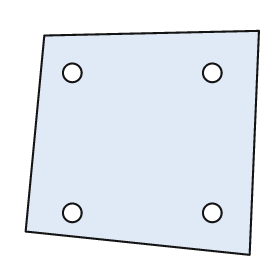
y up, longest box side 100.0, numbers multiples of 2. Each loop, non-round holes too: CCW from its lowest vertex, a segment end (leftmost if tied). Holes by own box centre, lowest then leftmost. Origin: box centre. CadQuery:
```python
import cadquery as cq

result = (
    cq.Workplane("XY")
    .moveTo(46.0, -48.0)
    .lineTo(50.0, 48.0)
    .lineTo(-42.0, 46.0)
    .lineTo(-50.0, -38.0)
    .close()
    .moveTo(-30.0, -30.0)
    .circle(4.0)
    .moveTo(30.0, -30.0)
    .circle(4.0)
    .moveTo(-30.0, 30.0)
    .circle(4.0)
    .moveTo(30.0, 30.0)
    .circle(4.0)
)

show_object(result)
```